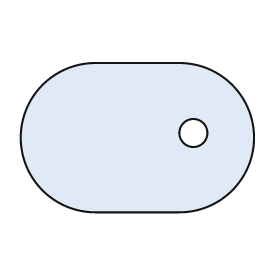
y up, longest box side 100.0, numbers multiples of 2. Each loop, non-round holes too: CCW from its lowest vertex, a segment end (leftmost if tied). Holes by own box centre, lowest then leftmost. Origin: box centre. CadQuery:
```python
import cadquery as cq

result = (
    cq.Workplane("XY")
    .moveTo(-18.0, -32.0)
    .lineTo(18.0, -32.0)
    .threePointArc((50.0, 0.0), (18.0, 32.0))
    .lineTo(-18.0, 32.0)
    .threePointArc((-50.0, 0.0), (-18.0, -32.0))
    .close()
    .moveTo(24.0, 2.0)
    .circle(6.0)
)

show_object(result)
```